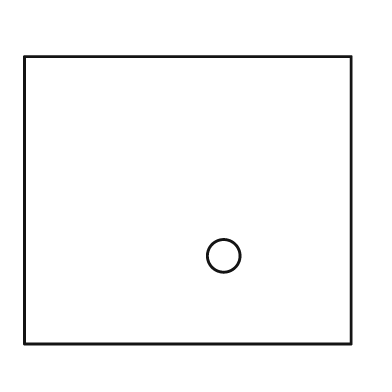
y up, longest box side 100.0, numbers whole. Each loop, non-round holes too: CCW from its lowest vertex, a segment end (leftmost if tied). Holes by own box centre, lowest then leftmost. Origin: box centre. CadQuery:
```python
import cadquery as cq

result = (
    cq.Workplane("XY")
    .moveTo(-50.0, -44.0)
    .lineTo(50.0, -44.0)
    .lineTo(50.0, 44.0)
    .lineTo(-50.0, 44.0)
    .close()
    .moveTo(11.0, -17.0)
    .circle(5.0)
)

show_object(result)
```